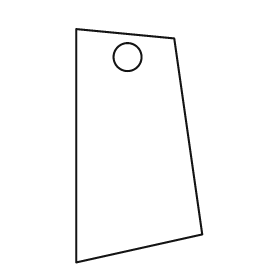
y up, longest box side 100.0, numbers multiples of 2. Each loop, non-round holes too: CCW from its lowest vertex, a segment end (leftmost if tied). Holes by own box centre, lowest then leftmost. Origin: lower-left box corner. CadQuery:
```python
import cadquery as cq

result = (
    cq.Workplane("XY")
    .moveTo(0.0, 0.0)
    .lineTo(54.0, 12.0)
    .lineTo(42.0, 96.0)
    .lineTo(0.0, 100.0)
    .close()
    .moveTo(22.0, 88.0)
    .circle(6.0)
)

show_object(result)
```